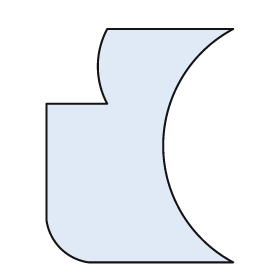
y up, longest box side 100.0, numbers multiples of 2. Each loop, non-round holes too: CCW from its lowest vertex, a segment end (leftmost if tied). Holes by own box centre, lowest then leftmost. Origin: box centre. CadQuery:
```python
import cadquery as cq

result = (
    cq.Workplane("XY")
    .moveTo(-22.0, -50.0)
    .lineTo(40.0, -50.0)
    .threePointArc((10.0, 0.0), (40.0, 50.0))
    .lineTo(-14.0, 50.0)
    .threePointArc((-18.0, 34.0), (-14.0, 18.0))
    .lineTo(-40.0, 18.0)
    .lineTo(-40.0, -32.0)
    .threePointArc((-34.0, -44.0), (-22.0, -50.0))
    .close()
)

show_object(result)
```